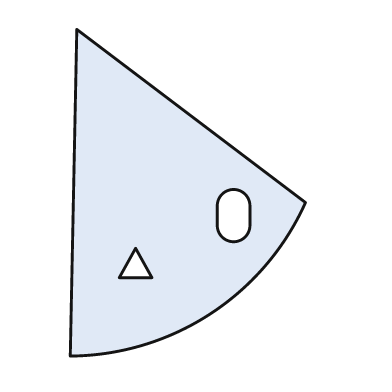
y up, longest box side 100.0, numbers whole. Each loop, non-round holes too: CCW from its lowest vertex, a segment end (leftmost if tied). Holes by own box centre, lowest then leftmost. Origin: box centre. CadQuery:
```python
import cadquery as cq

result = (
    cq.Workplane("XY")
    .moveTo(-36.0, -50.0)
    .threePointArc((7.0, -37.0), (36.0, -3.0))
    .lineTo(-34.0, 50.0)
    .close()
    .moveTo(-21.0, -26.0)
    .lineTo(-11.0, -26.0)
    .lineTo(-16.0, -17.0)
    .close()
    .moveTo(9.0, -10.0)
    .threePointArc((14.0, -15.0), (19.0, -10.0))
    .lineTo(19.0, -4.0)
    .threePointArc((14.0, 1.0), (9.0, -4.0))
    .close()
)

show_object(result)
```